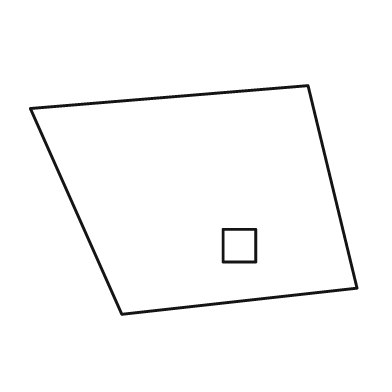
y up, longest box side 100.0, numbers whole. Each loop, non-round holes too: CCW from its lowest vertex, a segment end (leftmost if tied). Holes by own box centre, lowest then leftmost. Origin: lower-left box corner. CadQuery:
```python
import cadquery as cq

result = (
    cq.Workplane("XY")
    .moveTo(28.0, 0.0)
    .lineTo(100.0, 8.0)
    .lineTo(85.0, 70.0)
    .lineTo(0.0, 63.0)
    .close()
    .moveTo(59.0, 16.0)
    .lineTo(69.0, 16.0)
    .lineTo(69.0, 26.0)
    .lineTo(59.0, 26.0)
    .close()
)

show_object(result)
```